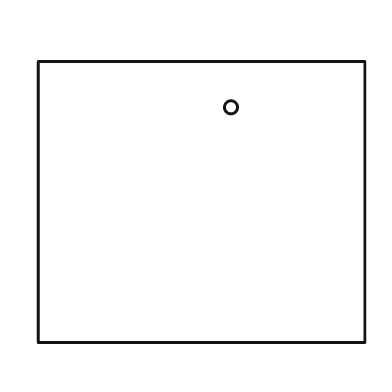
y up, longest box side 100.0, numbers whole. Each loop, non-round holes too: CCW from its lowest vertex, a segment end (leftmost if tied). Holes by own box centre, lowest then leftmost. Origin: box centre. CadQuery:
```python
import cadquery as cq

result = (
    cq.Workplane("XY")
    .moveTo(-50.0, -43.0)
    .lineTo(50.0, -43.0)
    .lineTo(50.0, 43.0)
    .lineTo(-50.0, 43.0)
    .close()
    .moveTo(9.0, 29.0)
    .circle(2.0)
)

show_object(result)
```